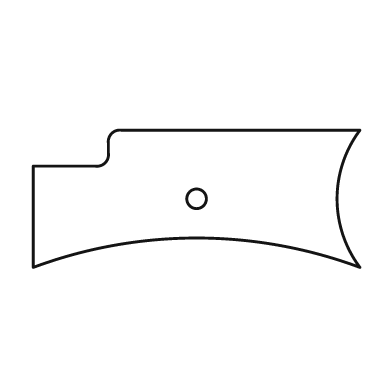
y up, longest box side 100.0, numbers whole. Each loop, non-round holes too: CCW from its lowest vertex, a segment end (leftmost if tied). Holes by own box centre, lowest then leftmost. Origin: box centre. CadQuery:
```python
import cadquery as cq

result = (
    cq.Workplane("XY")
    .moveTo(-50.0, -21.0)
    .threePointArc((0.0, -12.0), (50.0, -21.0))
    .threePointArc((43.0, 0.0), (50.0, 21.0))
    .lineTo(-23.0, 21.0)
    .threePointArc((-26.0, 20.0), (-27.0, 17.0))
    .lineTo(-27.0, 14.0)
    .threePointArc((-28.0, 11.0), (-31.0, 10.0))
    .lineTo(-50.0, 10.0)
    .close()
    .moveTo(0.0, 0.0)
    .circle(3.0)
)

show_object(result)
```